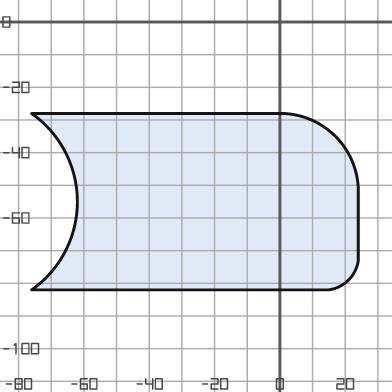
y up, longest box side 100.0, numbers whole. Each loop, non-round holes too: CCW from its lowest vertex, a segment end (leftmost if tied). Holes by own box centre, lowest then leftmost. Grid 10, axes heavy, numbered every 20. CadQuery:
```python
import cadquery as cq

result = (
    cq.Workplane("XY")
    .moveTo(-76.0, -82.0)
    .lineTo(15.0, -82.0)
    .threePointArc((21.0, -79.0), (24.0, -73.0))
    .lineTo(24.0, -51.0)
    .threePointArc((17.0, -35.0), (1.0, -28.0))
    .lineTo(-76.0, -28.0)
    .threePointArc((-62.0, -55.0), (-76.0, -82.0))
    .close()
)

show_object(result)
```